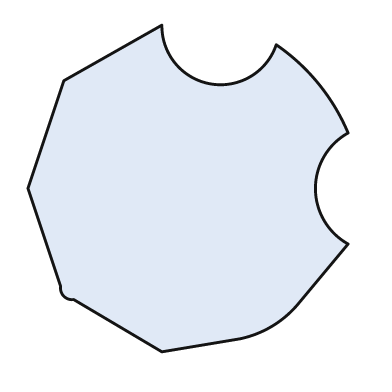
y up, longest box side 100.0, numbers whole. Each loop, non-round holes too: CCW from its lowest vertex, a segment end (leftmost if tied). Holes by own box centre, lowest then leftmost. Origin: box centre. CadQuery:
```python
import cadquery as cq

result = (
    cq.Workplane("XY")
    .moveTo(-8.0, -50.0)
    .lineTo(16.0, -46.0)
    .threePointArc((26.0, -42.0), (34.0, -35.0))
    .lineTo(49.0, -17.0)
    .threePointArc((39.0, 0.0), (49.0, 17.0))
    .threePointArc((40.0, 32.0), (27.0, 44.0))
    .threePointArc((7.0, 32.0), (-8.0, 50.0))
    .lineTo(-38.0, 33.0)
    .lineTo(-49.0, 0.0)
    .lineTo(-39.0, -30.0)
    .threePointArc((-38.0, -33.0), (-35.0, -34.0))
    .close()
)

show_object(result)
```